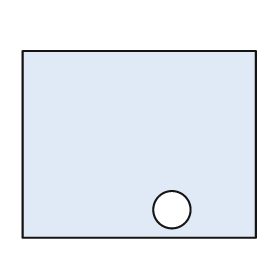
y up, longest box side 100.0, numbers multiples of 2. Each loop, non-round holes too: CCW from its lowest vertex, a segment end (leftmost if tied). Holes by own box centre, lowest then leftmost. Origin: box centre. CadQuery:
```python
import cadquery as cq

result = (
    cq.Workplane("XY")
    .moveTo(-50.0, -40.0)
    .lineTo(50.0, -40.0)
    .lineTo(50.0, 40.0)
    .lineTo(-50.0, 40.0)
    .close()
    .moveTo(14.0, -28.0)
    .circle(8.0)
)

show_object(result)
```